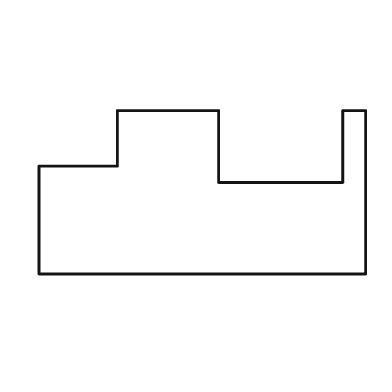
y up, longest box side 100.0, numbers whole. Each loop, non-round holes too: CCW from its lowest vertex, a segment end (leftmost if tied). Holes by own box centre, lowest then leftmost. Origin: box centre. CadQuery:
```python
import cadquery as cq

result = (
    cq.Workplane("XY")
    .moveTo(-50.0, -25.0)
    .lineTo(50.0, -25.0)
    .lineTo(50.0, 25.0)
    .lineTo(43.0, 25.0)
    .lineTo(43.0, 3.0)
    .lineTo(5.0, 3.0)
    .lineTo(5.0, 25.0)
    .lineTo(-26.0, 25.0)
    .lineTo(-26.0, 8.0)
    .lineTo(-50.0, 8.0)
    .close()
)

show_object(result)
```